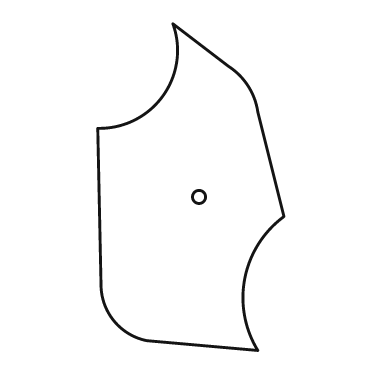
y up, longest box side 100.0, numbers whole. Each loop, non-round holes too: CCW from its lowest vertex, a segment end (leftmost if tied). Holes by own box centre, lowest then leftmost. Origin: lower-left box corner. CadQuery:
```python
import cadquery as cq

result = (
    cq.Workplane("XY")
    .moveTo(49.0, 0.0)
    .threePointArc((45.0, 22.0), (57.0, 41.0))
    .lineTo(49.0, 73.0)
    .threePointArc((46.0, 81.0), (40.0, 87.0))
    .lineTo(23.0, 100.0)
    .threePointArc((20.0, 78.0), (0.0, 68.0))
    .lineTo(1.0, 20.0)
    .threePointArc((5.0, 9.0), (15.0, 3.0))
    .close()
    .moveTo(31.0, 47.0)
    .circle(2.0)
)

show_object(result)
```